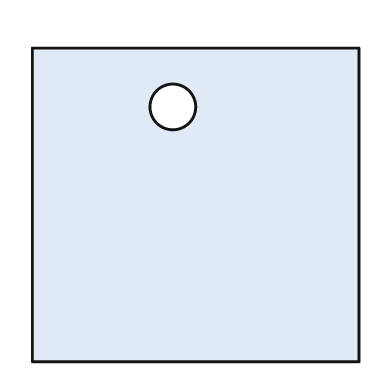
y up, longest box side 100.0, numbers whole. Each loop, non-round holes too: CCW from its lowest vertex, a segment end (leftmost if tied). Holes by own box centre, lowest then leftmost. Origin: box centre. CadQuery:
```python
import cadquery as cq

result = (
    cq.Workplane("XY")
    .moveTo(-50.0, -48.0)
    .lineTo(50.0, -48.0)
    .lineTo(50.0, 48.0)
    .lineTo(-50.0, 48.0)
    .close()
    .moveTo(-7.0, 30.0)
    .circle(7.0)
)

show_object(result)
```